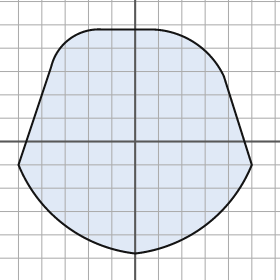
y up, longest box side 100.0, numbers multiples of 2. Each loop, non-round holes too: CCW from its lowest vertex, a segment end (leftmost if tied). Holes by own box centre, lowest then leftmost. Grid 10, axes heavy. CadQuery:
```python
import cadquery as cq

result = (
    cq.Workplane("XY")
    .moveTo(0.0, -48.0)
    .threePointArc((30.0, -36.0), (50.0, -10.0))
    .lineTo(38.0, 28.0)
    .threePointArc((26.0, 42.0), (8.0, 48.0))
    .lineTo(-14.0, 48.0)
    .threePointArc((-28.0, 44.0), (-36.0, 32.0))
    .lineTo(-50.0, -10.0)
    .threePointArc((-30.0, -36.0), (0.0, -48.0))
    .close()
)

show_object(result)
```